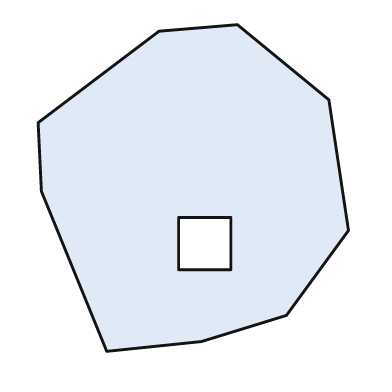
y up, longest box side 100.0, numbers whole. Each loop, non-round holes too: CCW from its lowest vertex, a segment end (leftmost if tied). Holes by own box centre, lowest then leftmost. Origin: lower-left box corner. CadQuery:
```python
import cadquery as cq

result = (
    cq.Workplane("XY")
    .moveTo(21.0, 0.0)
    .lineTo(50.0, 3.0)
    .lineTo(76.0, 11.0)
    .lineTo(95.0, 37.0)
    .lineTo(89.0, 77.0)
    .lineTo(61.0, 100.0)
    .lineTo(37.0, 98.0)
    .lineTo(0.0, 70.0)
    .lineTo(1.0, 49.0)
    .close()
    .moveTo(43.0, 25.0)
    .lineTo(59.0, 25.0)
    .lineTo(59.0, 41.0)
    .lineTo(43.0, 41.0)
    .close()
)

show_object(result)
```